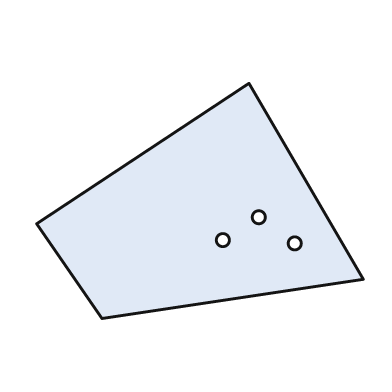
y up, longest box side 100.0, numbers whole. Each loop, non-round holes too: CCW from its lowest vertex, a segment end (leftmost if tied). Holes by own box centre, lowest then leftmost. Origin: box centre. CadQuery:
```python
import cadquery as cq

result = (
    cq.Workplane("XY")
    .moveTo(-30.0, -36.0)
    .lineTo(50.0, -24.0)
    .lineTo(15.0, 36.0)
    .lineTo(-50.0, -7.0)
    .close()
    .moveTo(29.0, -13.0)
    .circle(2.0)
    .moveTo(7.0, -12.0)
    .circle(2.0)
    .moveTo(18.0, -5.0)
    .circle(2.0)
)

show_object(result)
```